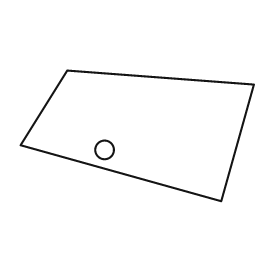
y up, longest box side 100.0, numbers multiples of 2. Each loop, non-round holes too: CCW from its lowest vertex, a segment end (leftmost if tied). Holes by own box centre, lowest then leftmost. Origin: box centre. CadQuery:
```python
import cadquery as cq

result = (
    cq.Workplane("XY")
    .moveTo(36.0, -28.0)
    .lineTo(50.0, 22.0)
    .lineTo(-30.0, 28.0)
    .lineTo(-50.0, -4.0)
    .close()
    .moveTo(-14.0, -6.0)
    .circle(4.0)
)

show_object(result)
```